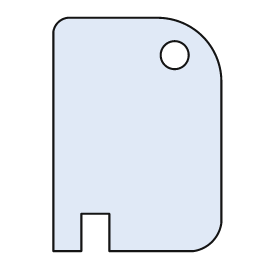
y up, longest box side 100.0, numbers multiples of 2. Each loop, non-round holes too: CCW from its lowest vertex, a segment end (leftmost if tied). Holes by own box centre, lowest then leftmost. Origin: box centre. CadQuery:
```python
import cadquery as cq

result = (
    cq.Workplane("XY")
    .moveTo(-36.0, -50.0)
    .lineTo(-24.0, -50.0)
    .lineTo(-24.0, -34.0)
    .lineTo(-12.0, -34.0)
    .lineTo(-12.0, -50.0)
    .lineTo(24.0, -50.0)
    .threePointArc((32.0, -46.0), (36.0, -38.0))
    .lineTo(36.0, 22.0)
    .threePointArc((28.0, 42.0), (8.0, 50.0))
    .lineTo(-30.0, 50.0)
    .threePointArc((-34.0, 48.0), (-36.0, 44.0))
    .close()
    .moveTo(16.0, 34.0)
    .circle(6.0)
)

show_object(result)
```